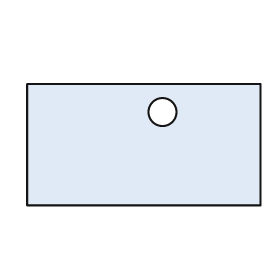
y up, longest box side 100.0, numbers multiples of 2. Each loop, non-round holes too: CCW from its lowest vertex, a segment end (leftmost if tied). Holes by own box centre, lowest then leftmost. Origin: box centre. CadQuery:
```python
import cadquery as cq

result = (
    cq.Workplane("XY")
    .moveTo(-50.0, -26.0)
    .lineTo(50.0, -26.0)
    .lineTo(50.0, 26.0)
    .lineTo(-50.0, 26.0)
    .close()
    .moveTo(8.0, 14.0)
    .circle(6.0)
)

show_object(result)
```